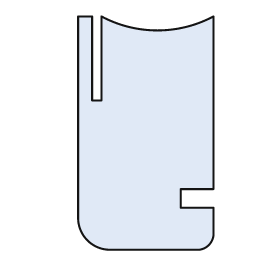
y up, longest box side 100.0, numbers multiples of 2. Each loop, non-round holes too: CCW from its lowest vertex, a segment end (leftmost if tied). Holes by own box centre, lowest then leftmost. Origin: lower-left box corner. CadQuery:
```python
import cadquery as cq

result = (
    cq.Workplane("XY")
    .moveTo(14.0, 0.0)
    .lineTo(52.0, 0.0)
    .threePointArc((56.0, 2.0), (58.0, 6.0))
    .lineTo(58.0, 18.0)
    .lineTo(44.0, 18.0)
    .lineTo(44.0, 26.0)
    .lineTo(58.0, 26.0)
    .lineTo(58.0, 100.0)
    .threePointArc((34.0, 94.0), (10.0, 100.0))
    .lineTo(10.0, 64.0)
    .lineTo(6.0, 64.0)
    .lineTo(6.0, 100.0)
    .lineTo(0.0, 100.0)
    .lineTo(0.0, 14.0)
    .threePointArc((4.0, 4.0), (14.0, 0.0))
    .close()
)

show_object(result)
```